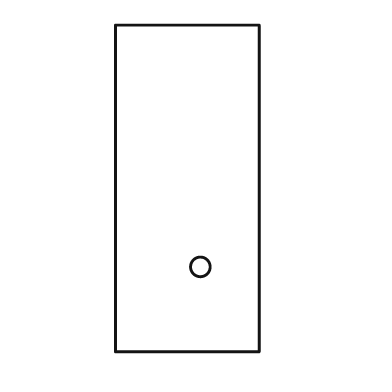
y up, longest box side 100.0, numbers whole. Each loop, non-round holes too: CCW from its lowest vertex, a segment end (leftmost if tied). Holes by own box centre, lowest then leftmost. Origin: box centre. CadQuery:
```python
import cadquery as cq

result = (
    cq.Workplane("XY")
    .moveTo(-22.0, -50.0)
    .lineTo(22.0, -50.0)
    .lineTo(22.0, 50.0)
    .lineTo(-22.0, 50.0)
    .close()
    .moveTo(4.0, -24.0)
    .circle(3.0)
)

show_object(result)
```